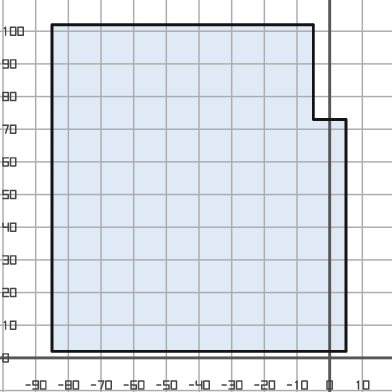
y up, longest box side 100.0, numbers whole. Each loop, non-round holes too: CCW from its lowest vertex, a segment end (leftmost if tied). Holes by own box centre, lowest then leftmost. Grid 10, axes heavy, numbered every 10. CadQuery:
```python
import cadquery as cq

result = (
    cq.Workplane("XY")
    .moveTo(-85.0, 2.0)
    .lineTo(5.0, 2.0)
    .lineTo(5.0, 73.0)
    .lineTo(-5.0, 73.0)
    .lineTo(-5.0, 102.0)
    .lineTo(-85.0, 102.0)
    .close()
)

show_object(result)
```